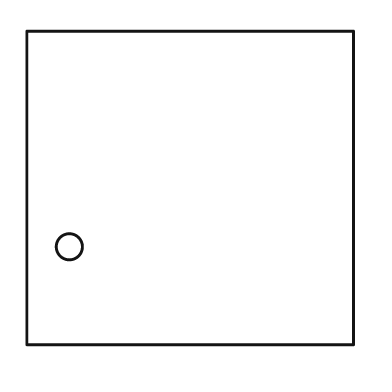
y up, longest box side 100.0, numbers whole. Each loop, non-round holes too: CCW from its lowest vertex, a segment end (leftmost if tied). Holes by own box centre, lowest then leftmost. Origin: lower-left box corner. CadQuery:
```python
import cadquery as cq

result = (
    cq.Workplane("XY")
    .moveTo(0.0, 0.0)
    .lineTo(100.0, 0.0)
    .lineTo(100.0, 96.0)
    .lineTo(0.0, 96.0)
    .close()
    .moveTo(13.0, 30.0)
    .circle(4.0)
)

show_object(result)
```